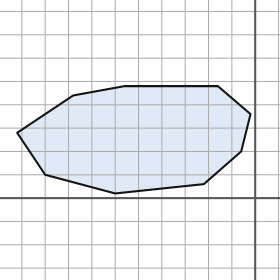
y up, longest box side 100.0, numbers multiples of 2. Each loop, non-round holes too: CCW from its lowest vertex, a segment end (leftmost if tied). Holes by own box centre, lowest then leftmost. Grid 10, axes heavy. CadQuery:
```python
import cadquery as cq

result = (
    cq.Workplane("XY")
    .moveTo(-60.0, 2.0)
    .lineTo(-22.0, 6.0)
    .lineTo(-6.0, 20.0)
    .lineTo(-2.0, 36.0)
    .lineTo(-16.0, 48.0)
    .lineTo(-56.0, 48.0)
    .lineTo(-78.0, 44.0)
    .lineTo(-102.0, 28.0)
    .lineTo(-90.0, 10.0)
    .close()
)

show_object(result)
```